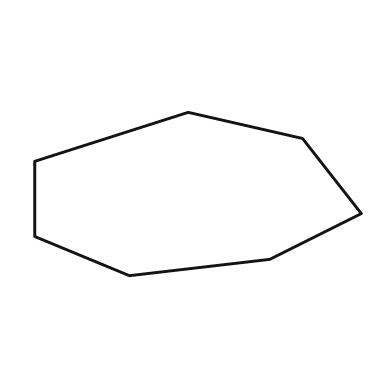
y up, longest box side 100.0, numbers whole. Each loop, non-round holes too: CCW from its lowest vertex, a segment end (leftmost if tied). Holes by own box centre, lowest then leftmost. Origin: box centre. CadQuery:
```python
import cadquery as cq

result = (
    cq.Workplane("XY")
    .moveTo(-21.0, -25.0)
    .lineTo(22.0, -20.0)
    .lineTo(50.0, -6.0)
    .lineTo(32.0, 17.0)
    .lineTo(-3.0, 25.0)
    .lineTo(-50.0, 10.0)
    .lineTo(-50.0, -13.0)
    .close()
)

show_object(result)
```